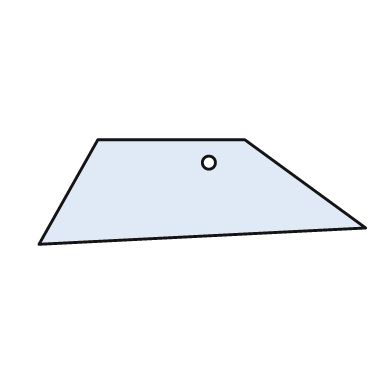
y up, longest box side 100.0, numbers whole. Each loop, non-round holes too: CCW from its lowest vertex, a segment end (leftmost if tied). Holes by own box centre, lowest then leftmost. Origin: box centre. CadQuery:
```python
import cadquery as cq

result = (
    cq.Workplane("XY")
    .moveTo(-50.0, -16.0)
    .lineTo(50.0, -11.0)
    .lineTo(13.0, 16.0)
    .lineTo(-32.0, 16.0)
    .close()
    .moveTo(2.0, 9.0)
    .circle(2.0)
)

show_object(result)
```